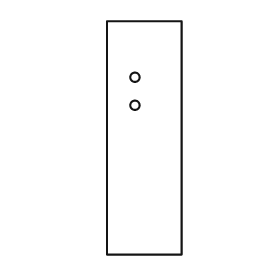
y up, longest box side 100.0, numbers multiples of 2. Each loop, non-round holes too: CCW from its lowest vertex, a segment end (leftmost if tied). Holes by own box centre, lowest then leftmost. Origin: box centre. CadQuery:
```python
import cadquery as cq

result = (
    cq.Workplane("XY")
    .moveTo(-16.0, -50.0)
    .lineTo(16.0, -50.0)
    .lineTo(16.0, 50.0)
    .lineTo(-16.0, 50.0)
    .close()
    .moveTo(-4.0, 14.0)
    .circle(2.0)
    .moveTo(-4.0, 26.0)
    .circle(2.0)
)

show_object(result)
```